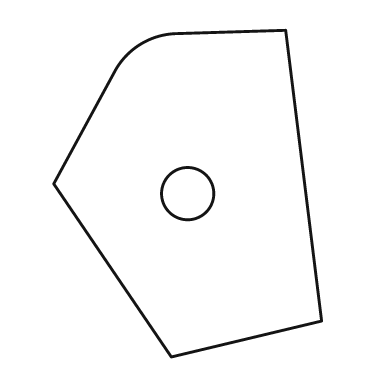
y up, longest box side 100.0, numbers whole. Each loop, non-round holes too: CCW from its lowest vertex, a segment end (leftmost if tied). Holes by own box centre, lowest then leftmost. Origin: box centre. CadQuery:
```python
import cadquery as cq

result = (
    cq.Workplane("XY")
    .moveTo(-5.0, -50.0)
    .lineTo(41.0, -39.0)
    .lineTo(30.0, 50.0)
    .lineTo(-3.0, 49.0)
    .threePointArc((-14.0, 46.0), (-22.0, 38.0))
    .lineTo(-41.0, 3.0)
    .close()
    .moveTo(0.0, 0.0)
    .circle(8.0)
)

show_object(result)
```